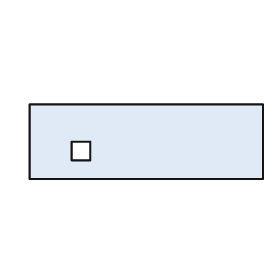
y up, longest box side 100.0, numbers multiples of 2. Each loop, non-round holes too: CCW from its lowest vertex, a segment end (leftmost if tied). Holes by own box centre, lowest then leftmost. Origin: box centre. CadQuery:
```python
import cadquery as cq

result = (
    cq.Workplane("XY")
    .moveTo(-50.0, -16.0)
    .lineTo(50.0, -16.0)
    .lineTo(50.0, 16.0)
    .lineTo(-50.0, 16.0)
    .close()
    .moveTo(-32.0, -8.0)
    .lineTo(-24.0, -8.0)
    .lineTo(-24.0, 0.0)
    .lineTo(-32.0, 0.0)
    .close()
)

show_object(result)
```